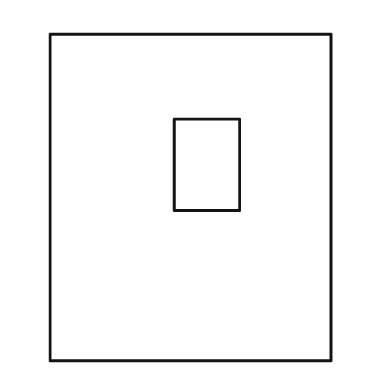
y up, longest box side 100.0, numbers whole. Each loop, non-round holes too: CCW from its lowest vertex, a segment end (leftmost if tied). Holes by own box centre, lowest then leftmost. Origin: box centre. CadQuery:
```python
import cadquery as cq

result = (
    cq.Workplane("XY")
    .moveTo(-43.0, -50.0)
    .lineTo(43.0, -50.0)
    .lineTo(43.0, 50.0)
    .lineTo(-43.0, 50.0)
    .close()
    .moveTo(-5.0, -4.0)
    .lineTo(15.0, -4.0)
    .lineTo(15.0, 24.0)
    .lineTo(-5.0, 24.0)
    .close()
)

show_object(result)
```